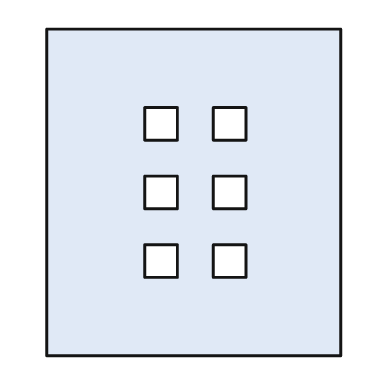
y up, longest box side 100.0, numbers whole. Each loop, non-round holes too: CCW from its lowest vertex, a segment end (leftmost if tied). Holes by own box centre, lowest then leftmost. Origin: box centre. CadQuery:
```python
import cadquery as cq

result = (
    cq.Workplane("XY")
    .moveTo(-45.0, -50.0)
    .lineTo(45.0, -50.0)
    .lineTo(45.0, 50.0)
    .lineTo(-45.0, 50.0)
    .close()
    .moveTo(-15.0, -26.0)
    .lineTo(-5.0, -26.0)
    .lineTo(-5.0, -16.0)
    .lineTo(-15.0, -16.0)
    .close()
    .moveTo(6.0, -26.0)
    .lineTo(16.0, -26.0)
    .lineTo(16.0, -16.0)
    .lineTo(6.0, -16.0)
    .close()
    .moveTo(-15.0, -5.0)
    .lineTo(-5.0, -5.0)
    .lineTo(-5.0, 5.0)
    .lineTo(-15.0, 5.0)
    .close()
    .moveTo(6.0, -5.0)
    .lineTo(16.0, -5.0)
    .lineTo(16.0, 5.0)
    .lineTo(6.0, 5.0)
    .close()
    .moveTo(-15.0, 16.0)
    .lineTo(-5.0, 16.0)
    .lineTo(-5.0, 26.0)
    .lineTo(-15.0, 26.0)
    .close()
    .moveTo(6.0, 16.0)
    .lineTo(16.0, 16.0)
    .lineTo(16.0, 26.0)
    .lineTo(6.0, 26.0)
    .close()
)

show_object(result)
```